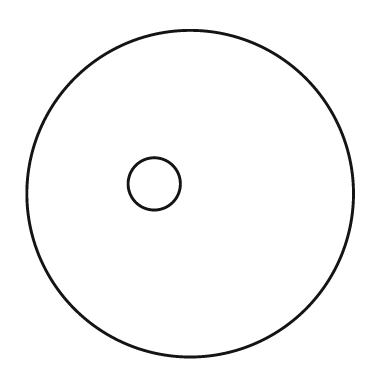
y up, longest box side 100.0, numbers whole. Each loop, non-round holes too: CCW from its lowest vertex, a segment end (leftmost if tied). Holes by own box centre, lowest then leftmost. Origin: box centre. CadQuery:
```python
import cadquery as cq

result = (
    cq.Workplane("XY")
    .moveTo(0.0, 0.0)
    .circle(50.0)
    .moveTo(-11.0, 3.0)
    .circle(8.0)
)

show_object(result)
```